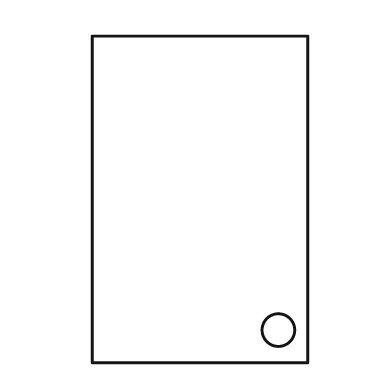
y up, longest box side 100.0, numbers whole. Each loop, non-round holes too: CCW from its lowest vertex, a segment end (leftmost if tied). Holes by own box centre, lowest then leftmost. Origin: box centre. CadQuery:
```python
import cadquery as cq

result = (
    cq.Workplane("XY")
    .moveTo(-33.0, -50.0)
    .lineTo(33.0, -50.0)
    .lineTo(33.0, 50.0)
    .lineTo(-33.0, 50.0)
    .close()
    .moveTo(24.0, -40.0)
    .circle(5.0)
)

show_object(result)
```